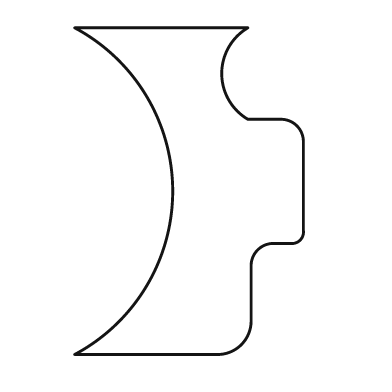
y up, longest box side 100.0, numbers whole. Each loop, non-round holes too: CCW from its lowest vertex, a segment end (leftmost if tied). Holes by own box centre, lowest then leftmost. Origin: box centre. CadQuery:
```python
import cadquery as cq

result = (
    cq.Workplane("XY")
    .moveTo(-35.0, -50.0)
    .lineTo(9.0, -50.0)
    .threePointArc((16.0, -47.0), (19.0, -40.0))
    .lineTo(19.0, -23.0)
    .threePointArc((21.0, -18.0), (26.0, -16.0))
    .lineTo(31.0, -16.0)
    .threePointArc((34.0, -15.0), (35.0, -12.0))
    .lineTo(35.0, 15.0)
    .threePointArc((33.0, 20.0), (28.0, 22.0))
    .lineTo(18.0, 22.0)
    .threePointArc((10.0, 36.0), (18.0, 50.0))
    .lineTo(-35.0, 50.0)
    .threePointArc((-5.0, 0.0), (-35.0, -50.0))
    .close()
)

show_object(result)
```